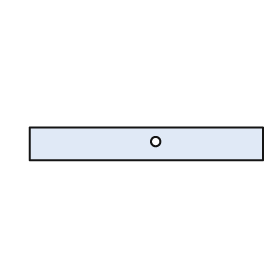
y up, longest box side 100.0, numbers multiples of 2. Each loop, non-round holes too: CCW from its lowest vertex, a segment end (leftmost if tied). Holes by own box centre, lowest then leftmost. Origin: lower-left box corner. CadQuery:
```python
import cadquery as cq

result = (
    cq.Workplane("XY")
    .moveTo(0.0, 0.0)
    .lineTo(100.0, 0.0)
    .lineTo(100.0, 14.0)
    .lineTo(0.0, 14.0)
    .close()
    .moveTo(54.0, 8.0)
    .circle(2.0)
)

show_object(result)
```